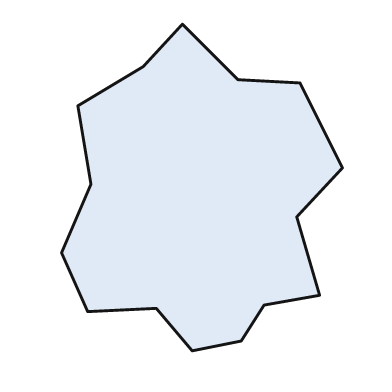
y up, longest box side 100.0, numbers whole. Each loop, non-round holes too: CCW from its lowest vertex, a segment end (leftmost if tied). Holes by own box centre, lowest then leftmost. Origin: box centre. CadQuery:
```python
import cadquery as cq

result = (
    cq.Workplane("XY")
    .moveTo(-3.0, -50.0)
    .lineTo(12.0, -47.0)
    .lineTo(19.0, -36.0)
    .lineTo(36.0, -33.0)
    .lineTo(29.0, -9.0)
    .lineTo(43.0, 6.0)
    .lineTo(30.0, 32.0)
    .lineTo(11.0, 33.0)
    .lineTo(-6.0, 50.0)
    .lineTo(-18.0, 37.0)
    .lineTo(-38.0, 25.0)
    .lineTo(-34.0, 1.0)
    .lineTo(-43.0, -20.0)
    .lineTo(-35.0, -38.0)
    .lineTo(-14.0, -37.0)
    .close()
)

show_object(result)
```